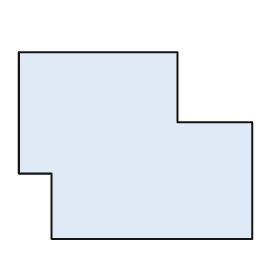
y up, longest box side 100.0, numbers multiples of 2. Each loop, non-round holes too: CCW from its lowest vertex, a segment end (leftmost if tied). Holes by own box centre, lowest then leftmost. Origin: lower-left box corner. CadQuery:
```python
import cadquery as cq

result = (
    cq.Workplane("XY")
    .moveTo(14.0, 0.0)
    .lineTo(100.0, 0.0)
    .lineTo(100.0, 50.0)
    .lineTo(68.0, 50.0)
    .lineTo(68.0, 80.0)
    .lineTo(0.0, 80.0)
    .lineTo(0.0, 28.0)
    .lineTo(14.0, 28.0)
    .close()
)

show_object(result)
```